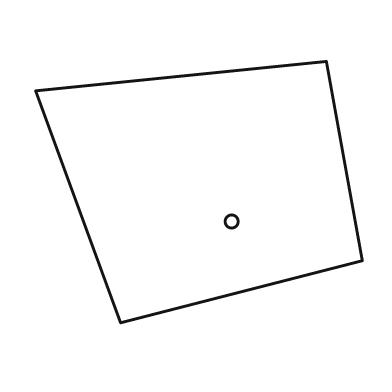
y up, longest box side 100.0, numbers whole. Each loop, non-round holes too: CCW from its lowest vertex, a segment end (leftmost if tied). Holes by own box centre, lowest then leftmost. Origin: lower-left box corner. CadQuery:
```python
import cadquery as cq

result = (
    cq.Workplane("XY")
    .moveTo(26.0, 0.0)
    .lineTo(100.0, 19.0)
    .lineTo(89.0, 80.0)
    .lineTo(0.0, 71.0)
    .close()
    .moveTo(60.0, 31.0)
    .circle(2.0)
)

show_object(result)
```